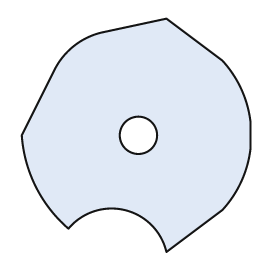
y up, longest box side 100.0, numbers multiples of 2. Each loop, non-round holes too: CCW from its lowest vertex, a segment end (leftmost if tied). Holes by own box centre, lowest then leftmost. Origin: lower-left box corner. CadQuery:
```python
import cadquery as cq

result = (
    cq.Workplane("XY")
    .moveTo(62.0, 0.0)
    .lineTo(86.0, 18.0)
    .threePointArc((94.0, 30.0), (98.0, 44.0))
    .lineTo(98.0, 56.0)
    .threePointArc((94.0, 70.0), (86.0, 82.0))
    .lineTo(62.0, 100.0)
    .lineTo(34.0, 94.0)
    .threePointArc((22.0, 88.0), (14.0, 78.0))
    .lineTo(0.0, 50.0)
    .threePointArc((6.0, 28.0), (20.0, 10.0))
    .threePointArc((44.0, 18.0), (62.0, 0.0))
    .close()
    .moveTo(50.0, 50.0)
    .circle(8.0)
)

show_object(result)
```